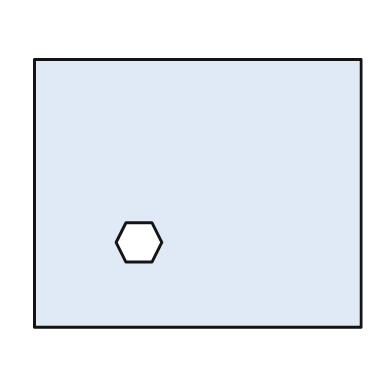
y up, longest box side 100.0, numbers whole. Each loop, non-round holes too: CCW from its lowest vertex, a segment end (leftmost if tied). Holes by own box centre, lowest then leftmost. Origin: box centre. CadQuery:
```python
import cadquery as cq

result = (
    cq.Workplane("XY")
    .moveTo(-50.0, -41.0)
    .lineTo(50.0, -41.0)
    .lineTo(50.0, 41.0)
    .lineTo(-50.0, 41.0)
    .close()
    .moveTo(-22.0, -21.0)
    .lineTo(-14.0, -21.0)
    .lineTo(-11.0, -15.0)
    .lineTo(-14.0, -9.0)
    .lineTo(-22.0, -9.0)
    .lineTo(-25.0, -15.0)
    .close()
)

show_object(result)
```